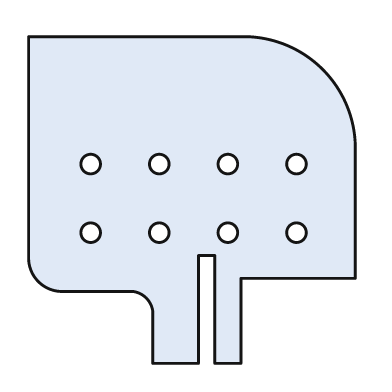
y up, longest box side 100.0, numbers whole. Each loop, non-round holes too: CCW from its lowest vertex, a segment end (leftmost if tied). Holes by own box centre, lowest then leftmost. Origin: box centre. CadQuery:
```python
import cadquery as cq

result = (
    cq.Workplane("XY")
    .moveTo(-12.0, -50.0)
    .lineTo(2.0, -50.0)
    .lineTo(2.0, -17.0)
    .lineTo(7.0, -17.0)
    .lineTo(7.0, -50.0)
    .lineTo(15.0, -50.0)
    .lineTo(15.0, -24.0)
    .lineTo(50.0, -24.0)
    .lineTo(50.0, 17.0)
    .threePointArc((40.0, 40.0), (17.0, 50.0))
    .lineTo(-50.0, 50.0)
    .lineTo(-50.0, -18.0)
    .threePointArc((-47.0, -25.0), (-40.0, -28.0))
    .lineTo(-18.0, -28.0)
    .threePointArc((-14.0, -30.0), (-12.0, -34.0))
    .close()
    .moveTo(-31.0, -10.0)
    .circle(3.0)
    .moveTo(-10.0, -10.0)
    .circle(3.0)
    .moveTo(11.0, -10.0)
    .circle(3.0)
    .moveTo(32.0, -10.0)
    .circle(3.0)
    .moveTo(-31.0, 11.0)
    .circle(3.0)
    .moveTo(-10.0, 11.0)
    .circle(3.0)
    .moveTo(11.0, 11.0)
    .circle(3.0)
    .moveTo(32.0, 11.0)
    .circle(3.0)
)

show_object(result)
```